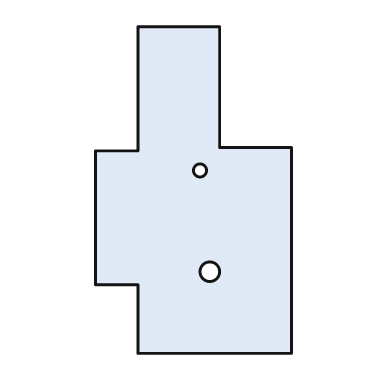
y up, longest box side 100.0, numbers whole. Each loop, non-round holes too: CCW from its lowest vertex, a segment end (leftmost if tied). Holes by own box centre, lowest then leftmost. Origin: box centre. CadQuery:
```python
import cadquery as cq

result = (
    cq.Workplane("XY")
    .moveTo(-17.0, -50.0)
    .lineTo(30.0, -50.0)
    .lineTo(30.0, 13.0)
    .lineTo(8.0, 13.0)
    .lineTo(8.0, 50.0)
    .lineTo(-17.0, 50.0)
    .lineTo(-17.0, 12.0)
    .lineTo(-30.0, 12.0)
    .lineTo(-30.0, -29.0)
    .lineTo(-17.0, -29.0)
    .close()
    .moveTo(5.0, -25.0)
    .circle(3.0)
    .moveTo(2.0, 6.0)
    .circle(2.0)
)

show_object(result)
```